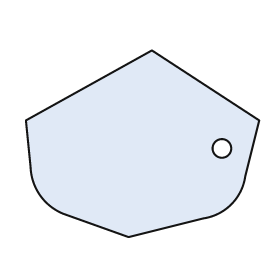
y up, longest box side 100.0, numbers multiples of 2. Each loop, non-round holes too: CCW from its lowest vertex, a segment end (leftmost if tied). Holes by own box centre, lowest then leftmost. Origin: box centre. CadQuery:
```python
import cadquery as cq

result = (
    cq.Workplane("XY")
    .moveTo(-6.0, -40.0)
    .lineTo(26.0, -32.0)
    .threePointArc((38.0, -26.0), (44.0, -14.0))
    .lineTo(50.0, 10.0)
    .lineTo(4.0, 40.0)
    .lineTo(-50.0, 10.0)
    .lineTo(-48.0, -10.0)
    .threePointArc((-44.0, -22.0), (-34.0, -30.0))
    .close()
    .moveTo(34.0, -2.0)
    .circle(4.0)
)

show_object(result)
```